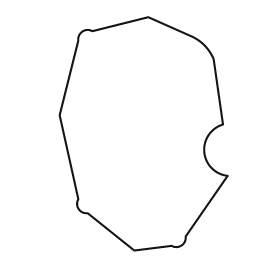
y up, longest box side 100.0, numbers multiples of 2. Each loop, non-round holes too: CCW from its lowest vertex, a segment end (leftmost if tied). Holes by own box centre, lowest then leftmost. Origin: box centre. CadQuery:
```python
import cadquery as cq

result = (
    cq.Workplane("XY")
    .moveTo(-4.0, -50.0)
    .lineTo(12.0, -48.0)
    .threePointArc((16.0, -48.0), (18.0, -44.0))
    .lineTo(36.0, -18.0)
    .threePointArc((26.0, -8.0), (34.0, 4.0))
    .lineTo(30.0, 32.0)
    .threePointArc((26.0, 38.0), (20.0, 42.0))
    .lineTo(2.0, 50.0)
    .lineTo(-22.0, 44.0)
    .threePointArc((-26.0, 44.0), (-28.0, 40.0))
    .lineTo(-36.0, 8.0)
    .lineTo(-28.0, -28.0)
    .threePointArc((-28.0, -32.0), (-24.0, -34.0))
    .close()
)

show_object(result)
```